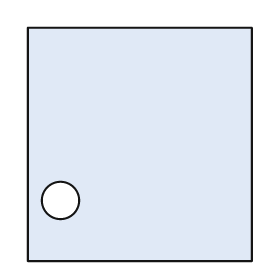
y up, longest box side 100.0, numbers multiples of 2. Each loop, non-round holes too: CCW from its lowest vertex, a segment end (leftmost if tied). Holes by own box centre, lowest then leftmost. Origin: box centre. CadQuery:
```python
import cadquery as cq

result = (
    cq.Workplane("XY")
    .moveTo(-48.0, -50.0)
    .lineTo(48.0, -50.0)
    .lineTo(48.0, 50.0)
    .lineTo(-48.0, 50.0)
    .close()
    .moveTo(-34.0, -24.0)
    .circle(8.0)
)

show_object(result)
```